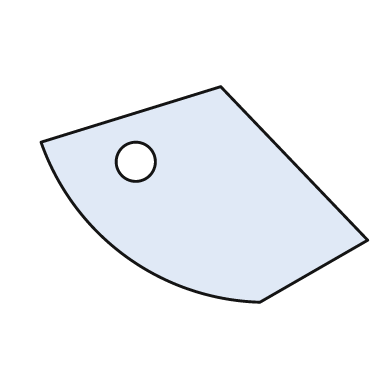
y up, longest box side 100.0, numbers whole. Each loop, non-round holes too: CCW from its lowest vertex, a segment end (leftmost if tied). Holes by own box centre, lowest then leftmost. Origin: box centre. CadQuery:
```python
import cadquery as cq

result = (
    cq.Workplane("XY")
    .moveTo(17.0, -33.0)
    .lineTo(50.0, -14.0)
    .lineTo(5.0, 33.0)
    .lineTo(-50.0, 16.0)
    .threePointArc((-24.0, -19.0), (17.0, -33.0))
    .close()
    .moveTo(-21.0, 10.0)
    .circle(6.0)
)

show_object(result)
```